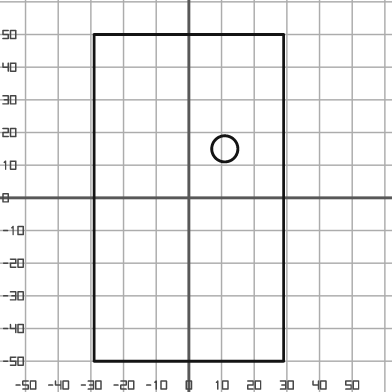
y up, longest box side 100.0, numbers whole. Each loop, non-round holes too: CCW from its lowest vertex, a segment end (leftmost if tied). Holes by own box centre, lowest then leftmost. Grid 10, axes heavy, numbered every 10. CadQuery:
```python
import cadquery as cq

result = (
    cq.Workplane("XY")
    .moveTo(-29.0, -50.0)
    .lineTo(29.0, -50.0)
    .lineTo(29.0, 50.0)
    .lineTo(-29.0, 50.0)
    .close()
    .moveTo(11.0, 15.0)
    .circle(4.0)
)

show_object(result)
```